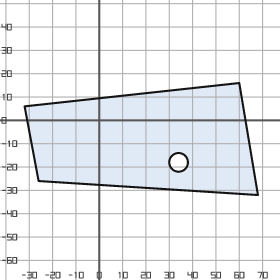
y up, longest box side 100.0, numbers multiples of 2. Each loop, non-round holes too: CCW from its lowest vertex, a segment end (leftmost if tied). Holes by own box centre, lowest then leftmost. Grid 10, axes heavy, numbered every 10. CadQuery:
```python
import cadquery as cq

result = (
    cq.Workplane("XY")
    .moveTo(68.0, -32.0)
    .lineTo(60.0, 16.0)
    .lineTo(-32.0, 6.0)
    .lineTo(-26.0, -26.0)
    .close()
    .moveTo(34.0, -18.0)
    .circle(4.0)
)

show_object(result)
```